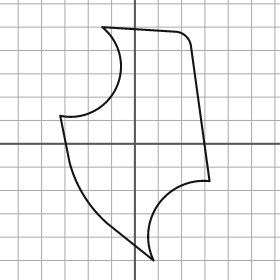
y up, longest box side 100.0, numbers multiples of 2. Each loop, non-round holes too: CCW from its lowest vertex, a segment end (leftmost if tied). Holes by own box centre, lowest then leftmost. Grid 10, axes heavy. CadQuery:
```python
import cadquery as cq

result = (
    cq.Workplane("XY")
    .moveTo(8.0, -50.0)
    .threePointArc((10.0, -26.0), (32.0, -16.0))
    .lineTo(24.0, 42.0)
    .threePointArc((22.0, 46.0), (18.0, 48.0))
    .lineTo(-14.0, 50.0)
    .threePointArc((-8.0, 24.0), (-32.0, 12.0))
    .lineTo(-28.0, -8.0)
    .threePointArc((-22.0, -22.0), (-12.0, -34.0))
    .close()
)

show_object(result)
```